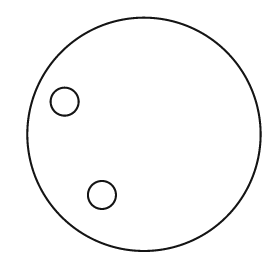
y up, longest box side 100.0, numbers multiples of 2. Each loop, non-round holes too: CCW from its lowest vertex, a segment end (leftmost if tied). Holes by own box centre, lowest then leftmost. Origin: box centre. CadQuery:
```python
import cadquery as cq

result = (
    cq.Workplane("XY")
    .moveTo(0.0, 0.0)
    .circle(50.0)
    .moveTo(-18.0, -26.0)
    .circle(6.0)
    .moveTo(-34.0, 14.0)
    .circle(6.0)
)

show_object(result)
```